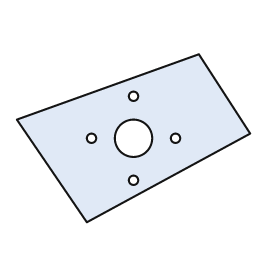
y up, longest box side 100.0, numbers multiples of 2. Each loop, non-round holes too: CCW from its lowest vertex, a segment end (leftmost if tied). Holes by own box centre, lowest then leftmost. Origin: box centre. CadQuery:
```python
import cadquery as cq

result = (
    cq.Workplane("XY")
    .moveTo(-20.0, -36.0)
    .lineTo(50.0, 2.0)
    .lineTo(28.0, 36.0)
    .lineTo(-50.0, 8.0)
    .close()
    .moveTo(0.0, -18.0)
    .circle(2.0)
    .moveTo(-18.0, 0.0)
    .circle(2.0)
    .moveTo(0.0, 0.0)
    .circle(8.0)
    .moveTo(18.0, 0.0)
    .circle(2.0)
    .moveTo(0.0, 18.0)
    .circle(2.0)
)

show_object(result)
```